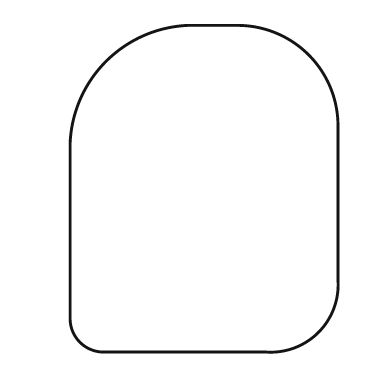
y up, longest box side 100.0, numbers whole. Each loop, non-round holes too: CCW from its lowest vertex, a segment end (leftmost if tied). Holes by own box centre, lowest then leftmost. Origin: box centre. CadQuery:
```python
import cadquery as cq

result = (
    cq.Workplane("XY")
    .moveTo(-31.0, -50.0)
    .lineTo(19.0, -50.0)
    .threePointArc((35.0, -44.0), (41.0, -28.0))
    .lineTo(41.0, 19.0)
    .threePointArc((32.0, 41.0), (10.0, 50.0))
    .lineTo(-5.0, 50.0)
    .threePointArc((-30.0, 39.0), (-41.0, 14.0))
    .lineTo(-41.0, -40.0)
    .threePointArc((-38.0, -47.0), (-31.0, -50.0))
    .close()
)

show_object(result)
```